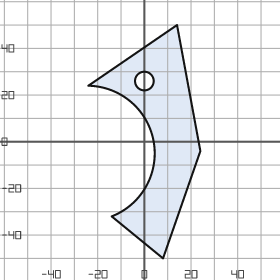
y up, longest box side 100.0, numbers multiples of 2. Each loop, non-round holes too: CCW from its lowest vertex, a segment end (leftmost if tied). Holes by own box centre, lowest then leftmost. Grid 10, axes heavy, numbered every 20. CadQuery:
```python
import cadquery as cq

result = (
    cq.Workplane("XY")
    .moveTo(8.0, -50.0)
    .lineTo(24.0, -4.0)
    .lineTo(14.0, 50.0)
    .lineTo(-24.0, 24.0)
    .threePointArc((4.0, 0.0), (-14.0, -32.0))
    .close()
    .moveTo(0.0, 26.0)
    .circle(4.0)
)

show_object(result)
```